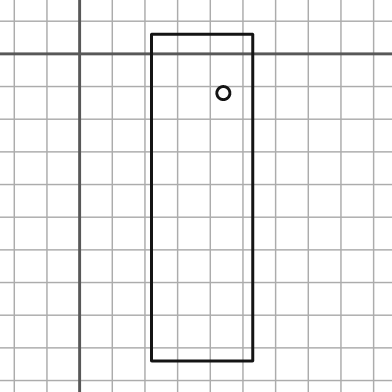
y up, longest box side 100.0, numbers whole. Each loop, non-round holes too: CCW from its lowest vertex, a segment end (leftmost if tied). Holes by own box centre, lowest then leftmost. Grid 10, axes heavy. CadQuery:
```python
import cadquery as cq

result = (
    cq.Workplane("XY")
    .moveTo(22.0, -94.0)
    .lineTo(53.0, -94.0)
    .lineTo(53.0, 6.0)
    .lineTo(22.0, 6.0)
    .close()
    .moveTo(44.0, -12.0)
    .circle(2.0)
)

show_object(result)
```